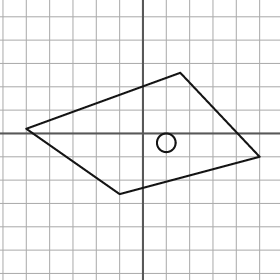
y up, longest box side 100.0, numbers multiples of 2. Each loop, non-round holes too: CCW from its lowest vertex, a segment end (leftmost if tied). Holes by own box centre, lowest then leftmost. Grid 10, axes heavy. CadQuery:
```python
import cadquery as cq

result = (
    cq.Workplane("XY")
    .moveTo(-10.0, -26.0)
    .lineTo(50.0, -10.0)
    .lineTo(16.0, 26.0)
    .lineTo(-50.0, 2.0)
    .close()
    .moveTo(10.0, -4.0)
    .circle(4.0)
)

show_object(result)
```